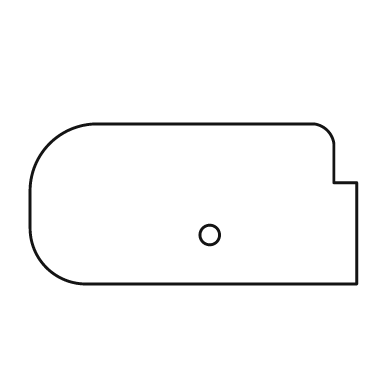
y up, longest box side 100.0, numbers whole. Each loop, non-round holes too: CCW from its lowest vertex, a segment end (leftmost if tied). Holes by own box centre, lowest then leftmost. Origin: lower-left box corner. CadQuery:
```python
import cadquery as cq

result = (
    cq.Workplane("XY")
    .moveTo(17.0, 0.0)
    .lineTo(100.0, 0.0)
    .lineTo(100.0, 31.0)
    .lineTo(93.0, 31.0)
    .lineTo(93.0, 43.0)
    .threePointArc((91.0, 47.0), (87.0, 49.0))
    .lineTo(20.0, 49.0)
    .threePointArc((6.0, 43.0), (0.0, 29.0))
    .lineTo(0.0, 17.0)
    .threePointArc((5.0, 5.0), (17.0, 0.0))
    .close()
    .moveTo(55.0, 15.0)
    .circle(3.0)
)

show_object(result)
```